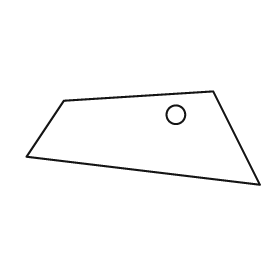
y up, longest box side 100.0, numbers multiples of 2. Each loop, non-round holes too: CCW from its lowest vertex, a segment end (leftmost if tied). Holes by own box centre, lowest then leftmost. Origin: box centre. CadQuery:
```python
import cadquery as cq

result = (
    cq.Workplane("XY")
    .moveTo(50.0, -20.0)
    .lineTo(30.0, 20.0)
    .lineTo(-34.0, 16.0)
    .lineTo(-50.0, -8.0)
    .close()
    .moveTo(14.0, 10.0)
    .circle(4.0)
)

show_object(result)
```